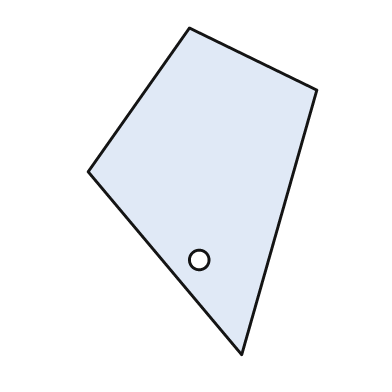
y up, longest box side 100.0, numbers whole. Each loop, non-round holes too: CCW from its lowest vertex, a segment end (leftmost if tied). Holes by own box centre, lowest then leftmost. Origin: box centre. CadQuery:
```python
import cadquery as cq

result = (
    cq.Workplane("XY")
    .moveTo(12.0, -50.0)
    .lineTo(35.0, 31.0)
    .lineTo(-4.0, 50.0)
    .lineTo(-35.0, 6.0)
    .close()
    .moveTo(-1.0, -21.0)
    .circle(3.0)
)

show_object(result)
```